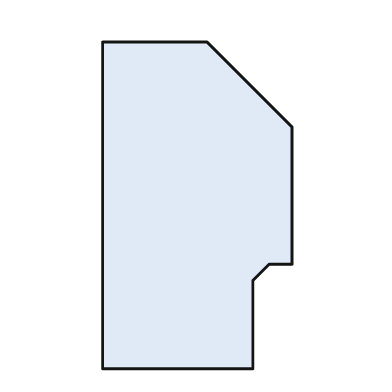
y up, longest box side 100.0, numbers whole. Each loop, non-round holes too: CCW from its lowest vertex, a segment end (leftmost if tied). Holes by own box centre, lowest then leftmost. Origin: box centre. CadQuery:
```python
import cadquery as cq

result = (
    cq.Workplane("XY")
    .moveTo(-29.0, -50.0)
    .lineTo(17.0, -50.0)
    .lineTo(17.0, -23.0)
    .lineTo(22.0, -18.0)
    .lineTo(29.0, -18.0)
    .lineTo(29.0, 24.0)
    .lineTo(3.0, 50.0)
    .lineTo(-29.0, 50.0)
    .close()
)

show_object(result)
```